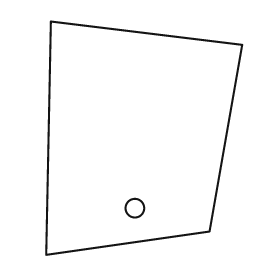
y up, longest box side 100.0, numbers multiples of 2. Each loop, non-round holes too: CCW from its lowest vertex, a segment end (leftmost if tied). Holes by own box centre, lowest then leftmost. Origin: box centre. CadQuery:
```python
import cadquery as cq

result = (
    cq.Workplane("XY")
    .moveTo(-42.0, -50.0)
    .lineTo(28.0, -40.0)
    .lineTo(42.0, 40.0)
    .lineTo(-40.0, 50.0)
    .close()
    .moveTo(-4.0, -30.0)
    .circle(4.0)
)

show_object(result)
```